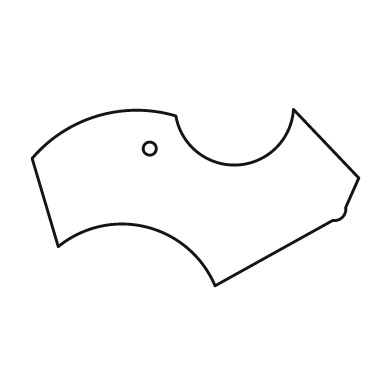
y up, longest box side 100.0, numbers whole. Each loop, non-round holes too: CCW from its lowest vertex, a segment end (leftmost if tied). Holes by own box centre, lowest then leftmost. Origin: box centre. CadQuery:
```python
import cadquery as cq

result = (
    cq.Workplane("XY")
    .moveTo(6.0, -27.0)
    .lineTo(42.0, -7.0)
    .threePointArc((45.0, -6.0), (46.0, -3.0))
    .lineTo(50.0, 6.0)
    .lineTo(30.0, 27.0)
    .threePointArc((13.0, 10.0), (-6.0, 25.0))
    .threePointArc((-30.0, 25.0), (-50.0, 12.0))
    .lineTo(-42.0, -15.0)
    .threePointArc((-15.0, -9.0), (6.0, -27.0))
    .close()
    .moveTo(-14.0, 15.0)
    .circle(2.0)
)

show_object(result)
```